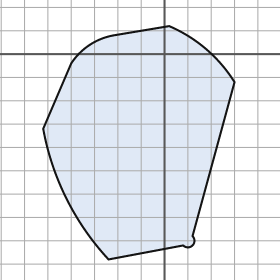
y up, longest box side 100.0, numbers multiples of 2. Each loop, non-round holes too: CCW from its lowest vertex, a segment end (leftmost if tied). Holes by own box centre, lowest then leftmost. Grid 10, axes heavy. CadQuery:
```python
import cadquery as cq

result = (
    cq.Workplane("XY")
    .moveTo(-24.0, -88.0)
    .lineTo(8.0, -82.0)
    .threePointArc((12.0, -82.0), (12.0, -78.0))
    .lineTo(30.0, -12.0)
    .threePointArc((18.0, 2.0), (2.0, 12.0))
    .lineTo(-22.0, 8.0)
    .threePointArc((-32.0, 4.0), (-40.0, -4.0))
    .lineTo(-52.0, -32.0)
    .threePointArc((-42.0, -62.0), (-24.0, -88.0))
    .close()
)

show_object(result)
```